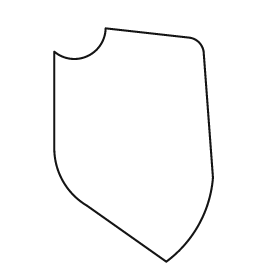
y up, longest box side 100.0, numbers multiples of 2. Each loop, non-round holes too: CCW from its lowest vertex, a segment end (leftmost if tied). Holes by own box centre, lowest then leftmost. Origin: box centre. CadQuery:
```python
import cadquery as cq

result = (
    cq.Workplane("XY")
    .moveTo(14.0, -50.0)
    .threePointArc((28.0, -34.0), (34.0, -14.0))
    .lineTo(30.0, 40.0)
    .threePointArc((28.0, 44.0), (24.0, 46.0))
    .lineTo(-12.0, 50.0)
    .threePointArc((-20.0, 38.0), (-34.0, 40.0))
    .lineTo(-34.0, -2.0)
    .threePointArc((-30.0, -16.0), (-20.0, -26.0))
    .close()
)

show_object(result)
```